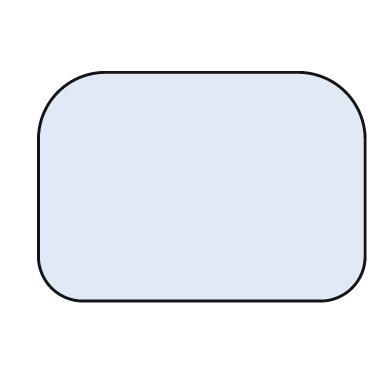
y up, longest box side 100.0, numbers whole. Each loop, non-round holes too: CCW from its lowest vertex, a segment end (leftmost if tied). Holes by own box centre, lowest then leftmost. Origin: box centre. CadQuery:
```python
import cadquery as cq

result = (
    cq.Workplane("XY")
    .moveTo(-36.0, -35.0)
    .lineTo(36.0, -35.0)
    .threePointArc((46.0, -31.0), (50.0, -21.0))
    .lineTo(50.0, 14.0)
    .threePointArc((44.0, 29.0), (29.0, 35.0))
    .lineTo(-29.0, 35.0)
    .threePointArc((-44.0, 29.0), (-50.0, 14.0))
    .lineTo(-50.0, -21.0)
    .threePointArc((-46.0, -31.0), (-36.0, -35.0))
    .close()
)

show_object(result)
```